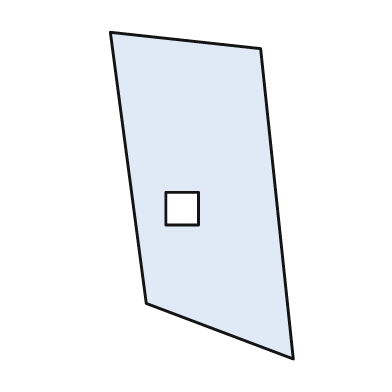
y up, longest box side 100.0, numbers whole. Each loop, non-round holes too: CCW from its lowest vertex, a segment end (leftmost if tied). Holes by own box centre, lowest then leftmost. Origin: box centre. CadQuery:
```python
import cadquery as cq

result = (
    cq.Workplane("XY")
    .moveTo(28.0, -50.0)
    .lineTo(18.0, 45.0)
    .lineTo(-28.0, 50.0)
    .lineTo(-17.0, -33.0)
    .close()
    .moveTo(-11.0, -9.0)
    .lineTo(-1.0, -9.0)
    .lineTo(-1.0, 1.0)
    .lineTo(-11.0, 1.0)
    .close()
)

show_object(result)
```